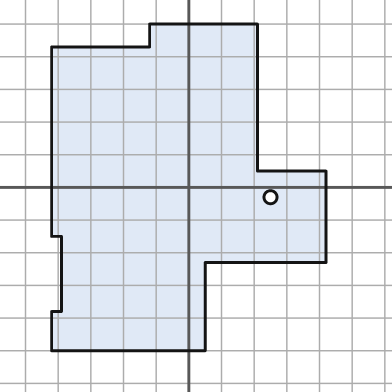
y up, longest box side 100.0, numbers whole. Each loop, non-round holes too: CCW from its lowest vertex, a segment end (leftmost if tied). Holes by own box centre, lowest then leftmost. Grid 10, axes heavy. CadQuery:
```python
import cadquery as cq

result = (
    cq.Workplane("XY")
    .moveTo(-42.0, -50.0)
    .lineTo(5.0, -50.0)
    .lineTo(5.0, -23.0)
    .lineTo(42.0, -23.0)
    .lineTo(42.0, 5.0)
    .lineTo(21.0, 5.0)
    .lineTo(21.0, 50.0)
    .lineTo(-12.0, 50.0)
    .lineTo(-12.0, 43.0)
    .lineTo(-42.0, 43.0)
    .lineTo(-42.0, -15.0)
    .lineTo(-39.0, -15.0)
    .lineTo(-39.0, -38.0)
    .lineTo(-42.0, -38.0)
    .close()
    .moveTo(25.0, -3.0)
    .circle(2.0)
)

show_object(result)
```